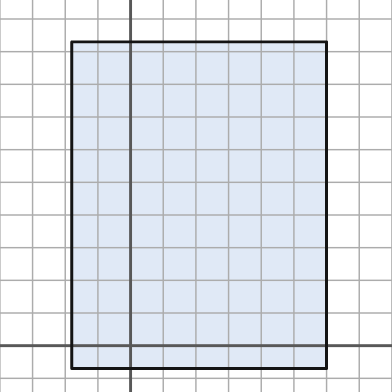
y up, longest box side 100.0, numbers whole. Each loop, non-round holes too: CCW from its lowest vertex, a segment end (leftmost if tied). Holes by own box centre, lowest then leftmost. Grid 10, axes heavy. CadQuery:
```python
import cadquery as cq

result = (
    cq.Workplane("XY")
    .moveTo(-18.0, -7.0)
    .lineTo(60.0, -7.0)
    .lineTo(60.0, 93.0)
    .lineTo(-18.0, 93.0)
    .close()
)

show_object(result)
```